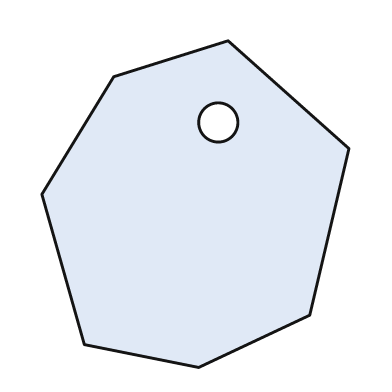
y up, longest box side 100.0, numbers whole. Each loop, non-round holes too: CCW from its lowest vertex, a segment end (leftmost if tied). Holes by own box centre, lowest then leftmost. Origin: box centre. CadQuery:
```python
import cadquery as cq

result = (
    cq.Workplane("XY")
    .moveTo(1.0, -50.0)
    .lineTo(35.0, -34.0)
    .lineTo(47.0, 17.0)
    .lineTo(10.0, 50.0)
    .lineTo(-25.0, 39.0)
    .lineTo(-47.0, 3.0)
    .lineTo(-34.0, -43.0)
    .close()
    .moveTo(7.0, 25.0)
    .circle(6.0)
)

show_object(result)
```